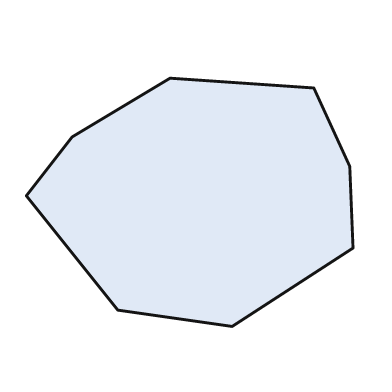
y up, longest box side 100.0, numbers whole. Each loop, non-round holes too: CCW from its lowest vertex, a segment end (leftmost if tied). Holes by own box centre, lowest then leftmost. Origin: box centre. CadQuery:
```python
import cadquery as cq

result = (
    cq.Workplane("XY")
    .moveTo(13.0, -38.0)
    .lineTo(50.0, -14.0)
    .lineTo(49.0, 11.0)
    .lineTo(38.0, 35.0)
    .lineTo(-6.0, 38.0)
    .lineTo(-36.0, 20.0)
    .lineTo(-50.0, 2.0)
    .lineTo(-22.0, -33.0)
    .close()
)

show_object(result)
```